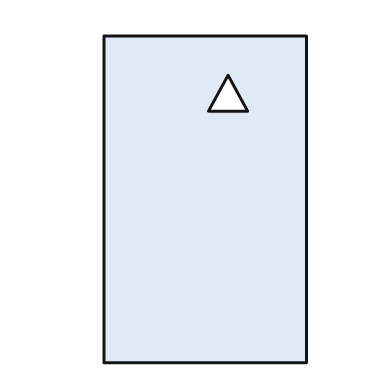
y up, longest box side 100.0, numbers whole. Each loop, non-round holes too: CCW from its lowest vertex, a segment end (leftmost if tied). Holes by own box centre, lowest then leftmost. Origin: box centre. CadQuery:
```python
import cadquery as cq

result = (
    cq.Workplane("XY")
    .moveTo(-31.0, -50.0)
    .lineTo(31.0, -50.0)
    .lineTo(31.0, 50.0)
    .lineTo(-31.0, 50.0)
    .close()
    .moveTo(1.0, 27.0)
    .lineTo(13.0, 27.0)
    .lineTo(7.0, 38.0)
    .close()
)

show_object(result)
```